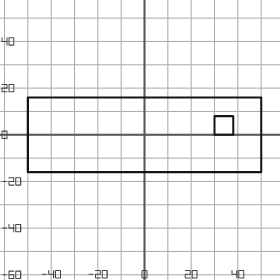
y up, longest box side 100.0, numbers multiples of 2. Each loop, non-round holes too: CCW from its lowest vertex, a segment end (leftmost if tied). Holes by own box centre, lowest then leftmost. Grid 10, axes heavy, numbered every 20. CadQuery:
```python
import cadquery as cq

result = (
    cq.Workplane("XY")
    .moveTo(-50.0, -16.0)
    .lineTo(50.0, -16.0)
    .lineTo(50.0, 16.0)
    .lineTo(-50.0, 16.0)
    .close()
    .moveTo(30.0, 0.0)
    .lineTo(38.0, 0.0)
    .lineTo(38.0, 8.0)
    .lineTo(30.0, 8.0)
    .close()
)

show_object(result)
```